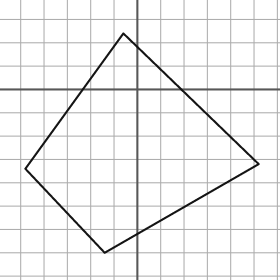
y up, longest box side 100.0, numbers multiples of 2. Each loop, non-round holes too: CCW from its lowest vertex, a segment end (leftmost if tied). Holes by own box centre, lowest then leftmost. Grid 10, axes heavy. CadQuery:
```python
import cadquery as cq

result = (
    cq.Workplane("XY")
    .moveTo(-14.0, -70.0)
    .lineTo(52.0, -32.0)
    .lineTo(-6.0, 24.0)
    .lineTo(-48.0, -34.0)
    .close()
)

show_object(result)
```